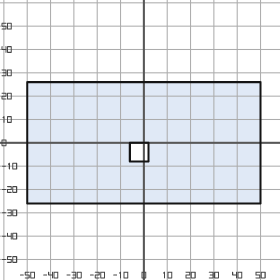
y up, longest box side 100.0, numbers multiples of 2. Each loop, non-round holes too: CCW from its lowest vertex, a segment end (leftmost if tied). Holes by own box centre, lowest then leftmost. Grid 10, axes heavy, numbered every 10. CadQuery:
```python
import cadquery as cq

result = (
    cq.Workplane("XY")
    .moveTo(-50.0, -26.0)
    .lineTo(50.0, -26.0)
    .lineTo(50.0, 26.0)
    .lineTo(-50.0, 26.0)
    .close()
    .moveTo(-6.0, -8.0)
    .lineTo(2.0, -8.0)
    .lineTo(2.0, 0.0)
    .lineTo(-6.0, 0.0)
    .close()
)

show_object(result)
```